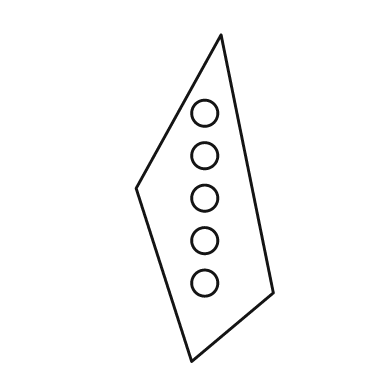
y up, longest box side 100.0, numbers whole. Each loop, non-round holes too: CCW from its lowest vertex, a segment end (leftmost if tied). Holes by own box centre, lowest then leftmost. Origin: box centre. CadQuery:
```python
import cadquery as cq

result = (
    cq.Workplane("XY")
    .moveTo(-4.0, -50.0)
    .lineTo(21.0, -29.0)
    .lineTo(5.0, 50.0)
    .lineTo(-21.0, 3.0)
    .close()
    .moveTo(0.0, -26.0)
    .circle(4.0)
    .moveTo(0.0, -13.0)
    .circle(4.0)
    .moveTo(0.0, 0.0)
    .circle(4.0)
    .moveTo(0.0, 13.0)
    .circle(4.0)
    .moveTo(0.0, 26.0)
    .circle(4.0)
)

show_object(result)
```